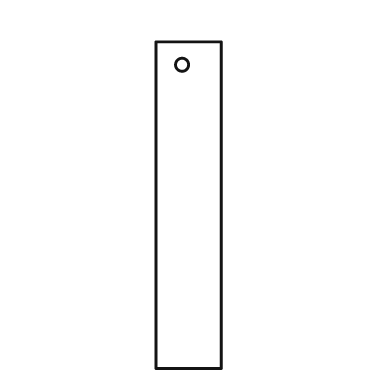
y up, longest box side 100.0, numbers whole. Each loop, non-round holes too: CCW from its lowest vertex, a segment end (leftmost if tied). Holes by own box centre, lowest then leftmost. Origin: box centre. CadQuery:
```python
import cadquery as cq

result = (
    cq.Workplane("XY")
    .moveTo(-10.0, -50.0)
    .lineTo(10.0, -50.0)
    .lineTo(10.0, 50.0)
    .lineTo(-10.0, 50.0)
    .close()
    .moveTo(-2.0, 43.0)
    .circle(2.0)
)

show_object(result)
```